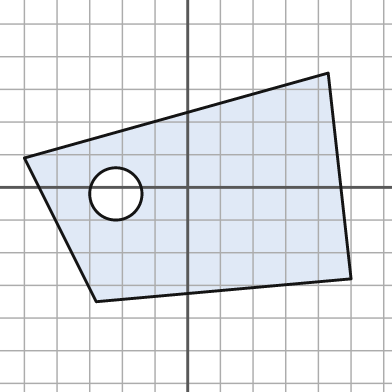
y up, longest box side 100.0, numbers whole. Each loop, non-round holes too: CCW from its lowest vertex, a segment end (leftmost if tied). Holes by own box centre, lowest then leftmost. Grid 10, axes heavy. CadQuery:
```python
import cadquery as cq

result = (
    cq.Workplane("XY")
    .moveTo(-28.0, -35.0)
    .lineTo(50.0, -28.0)
    .lineTo(43.0, 35.0)
    .lineTo(-50.0, 9.0)
    .close()
    .moveTo(-22.0, -2.0)
    .circle(8.0)
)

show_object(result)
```